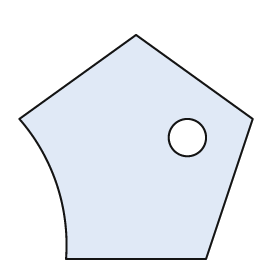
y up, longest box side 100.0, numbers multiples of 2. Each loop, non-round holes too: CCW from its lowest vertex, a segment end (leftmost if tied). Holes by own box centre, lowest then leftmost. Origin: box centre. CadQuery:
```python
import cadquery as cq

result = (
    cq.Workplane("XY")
    .moveTo(-30.0, -48.0)
    .lineTo(30.0, -48.0)
    .lineTo(50.0, 12.0)
    .lineTo(0.0, 48.0)
    .lineTo(-50.0, 12.0)
    .threePointArc((-34.0, -16.0), (-30.0, -48.0))
    .close()
    .moveTo(22.0, 4.0)
    .circle(8.0)
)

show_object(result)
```